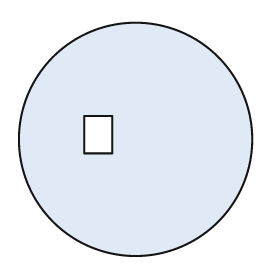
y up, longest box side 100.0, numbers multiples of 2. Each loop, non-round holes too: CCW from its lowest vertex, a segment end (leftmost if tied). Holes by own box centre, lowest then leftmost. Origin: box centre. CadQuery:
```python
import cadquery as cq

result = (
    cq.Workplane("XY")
    .moveTo(0.0, 0.0)
    .circle(50.0)
    .moveTo(-22.0, -6.0)
    .lineTo(-10.0, -6.0)
    .lineTo(-10.0, 10.0)
    .lineTo(-22.0, 10.0)
    .close()
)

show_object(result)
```